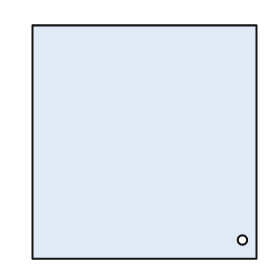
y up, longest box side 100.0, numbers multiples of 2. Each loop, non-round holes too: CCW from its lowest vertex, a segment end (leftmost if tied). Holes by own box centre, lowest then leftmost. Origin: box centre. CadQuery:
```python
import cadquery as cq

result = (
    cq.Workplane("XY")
    .moveTo(-48.0, -50.0)
    .lineTo(48.0, -50.0)
    .lineTo(48.0, 50.0)
    .lineTo(-48.0, 50.0)
    .close()
    .moveTo(42.0, -42.0)
    .circle(2.0)
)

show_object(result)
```